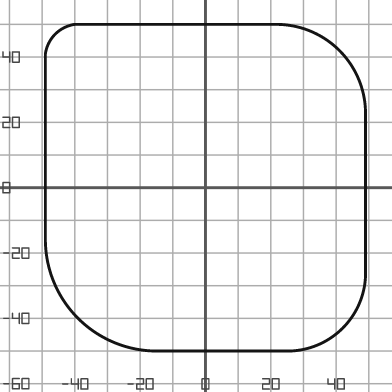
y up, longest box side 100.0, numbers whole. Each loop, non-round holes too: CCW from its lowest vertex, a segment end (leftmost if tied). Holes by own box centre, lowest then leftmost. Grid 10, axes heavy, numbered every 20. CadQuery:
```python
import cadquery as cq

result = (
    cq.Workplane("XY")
    .moveTo(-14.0, -50.0)
    .lineTo(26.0, -50.0)
    .threePointArc((42.0, -43.0), (49.0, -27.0))
    .lineTo(49.0, 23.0)
    .threePointArc((41.0, 42.0), (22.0, 50.0))
    .lineTo(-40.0, 50.0)
    .threePointArc((-46.0, 47.0), (-49.0, 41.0))
    .lineTo(-49.0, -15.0)
    .threePointArc((-39.0, -40.0), (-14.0, -50.0))
    .close()
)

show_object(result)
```